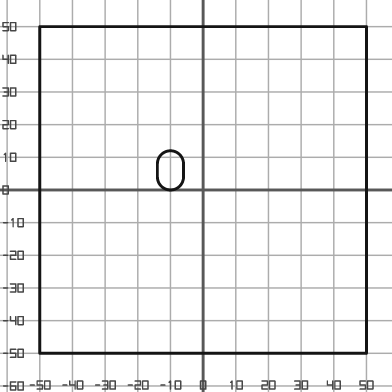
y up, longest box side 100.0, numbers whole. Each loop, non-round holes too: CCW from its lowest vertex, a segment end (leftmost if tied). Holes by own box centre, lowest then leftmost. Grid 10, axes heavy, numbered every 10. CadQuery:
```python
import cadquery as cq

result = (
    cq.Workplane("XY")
    .moveTo(-50.0, -50.0)
    .lineTo(50.0, -50.0)
    .lineTo(50.0, 50.0)
    .lineTo(-50.0, 50.0)
    .close()
    .moveTo(-14.0, 4.0)
    .threePointArc((-10.0, 0.0), (-6.0, 4.0))
    .lineTo(-6.0, 8.0)
    .threePointArc((-10.0, 12.0), (-14.0, 8.0))
    .close()
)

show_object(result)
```